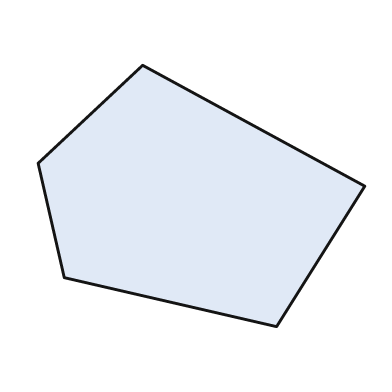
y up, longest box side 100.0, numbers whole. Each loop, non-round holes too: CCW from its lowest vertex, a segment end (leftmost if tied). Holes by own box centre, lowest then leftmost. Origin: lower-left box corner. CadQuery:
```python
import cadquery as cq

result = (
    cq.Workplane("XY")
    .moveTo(73.0, 0.0)
    .lineTo(100.0, 43.0)
    .lineTo(32.0, 80.0)
    .lineTo(0.0, 50.0)
    .lineTo(8.0, 15.0)
    .close()
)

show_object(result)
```